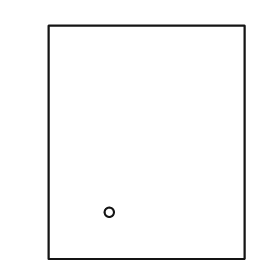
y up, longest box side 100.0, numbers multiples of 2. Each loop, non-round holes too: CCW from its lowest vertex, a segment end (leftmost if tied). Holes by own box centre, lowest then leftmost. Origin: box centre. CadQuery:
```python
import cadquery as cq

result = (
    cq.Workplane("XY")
    .moveTo(-42.0, -50.0)
    .lineTo(42.0, -50.0)
    .lineTo(42.0, 50.0)
    .lineTo(-42.0, 50.0)
    .close()
    .moveTo(-16.0, -30.0)
    .circle(2.0)
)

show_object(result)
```